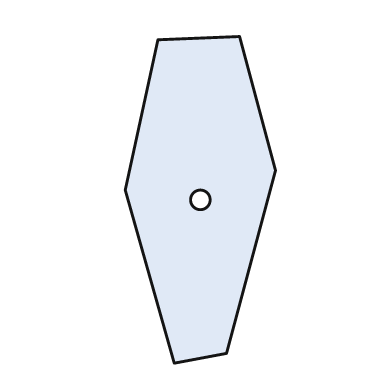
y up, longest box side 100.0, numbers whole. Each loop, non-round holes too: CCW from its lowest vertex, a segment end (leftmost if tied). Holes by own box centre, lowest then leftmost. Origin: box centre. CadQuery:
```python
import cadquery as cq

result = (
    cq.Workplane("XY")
    .moveTo(-8.0, -50.0)
    .lineTo(8.0, -47.0)
    .lineTo(23.0, 9.0)
    .lineTo(12.0, 50.0)
    .lineTo(-13.0, 49.0)
    .lineTo(-23.0, 3.0)
    .close()
    .moveTo(0.0, 0.0)
    .circle(3.0)
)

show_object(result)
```